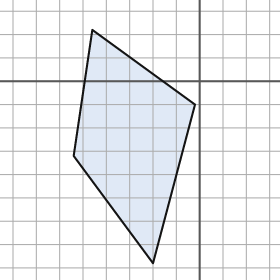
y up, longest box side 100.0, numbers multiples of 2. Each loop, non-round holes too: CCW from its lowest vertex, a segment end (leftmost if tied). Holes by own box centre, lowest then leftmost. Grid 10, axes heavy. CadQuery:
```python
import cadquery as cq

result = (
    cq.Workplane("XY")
    .moveTo(-20.0, -78.0)
    .lineTo(-2.0, -10.0)
    .lineTo(-46.0, 22.0)
    .lineTo(-54.0, -32.0)
    .close()
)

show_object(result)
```